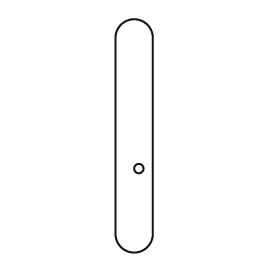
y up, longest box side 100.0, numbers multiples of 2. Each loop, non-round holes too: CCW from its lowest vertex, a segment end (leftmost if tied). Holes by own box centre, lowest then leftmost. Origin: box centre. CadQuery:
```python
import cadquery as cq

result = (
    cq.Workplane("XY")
    .moveTo(-8.0, -42.0)
    .threePointArc((0.0, -50.0), (8.0, -42.0))
    .lineTo(8.0, 42.0)
    .threePointArc((0.0, 50.0), (-8.0, 42.0))
    .close()
    .moveTo(2.0, -14.0)
    .circle(2.0)
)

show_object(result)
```